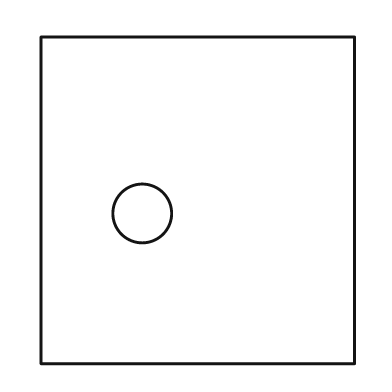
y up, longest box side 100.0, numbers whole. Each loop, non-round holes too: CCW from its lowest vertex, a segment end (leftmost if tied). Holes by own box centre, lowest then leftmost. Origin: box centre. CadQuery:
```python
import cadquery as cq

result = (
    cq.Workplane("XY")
    .moveTo(-48.0, -50.0)
    .lineTo(48.0, -50.0)
    .lineTo(48.0, 50.0)
    .lineTo(-48.0, 50.0)
    .close()
    .moveTo(-17.0, -4.0)
    .circle(9.0)
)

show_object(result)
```